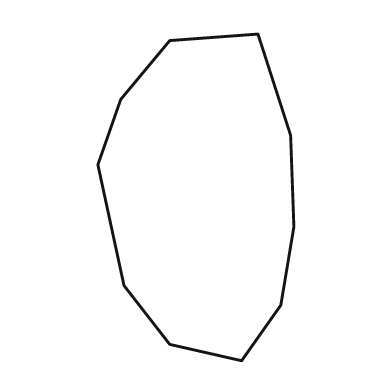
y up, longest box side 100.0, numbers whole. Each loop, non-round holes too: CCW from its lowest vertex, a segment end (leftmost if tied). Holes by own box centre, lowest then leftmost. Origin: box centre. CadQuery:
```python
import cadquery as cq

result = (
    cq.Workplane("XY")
    .moveTo(14.0, -50.0)
    .lineTo(26.0, -33.0)
    .lineTo(30.0, -9.0)
    .lineTo(29.0, 19.0)
    .lineTo(19.0, 50.0)
    .lineTo(-8.0, 48.0)
    .lineTo(-23.0, 30.0)
    .lineTo(-30.0, 10.0)
    .lineTo(-22.0, -27.0)
    .lineTo(-8.0, -45.0)
    .close()
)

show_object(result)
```